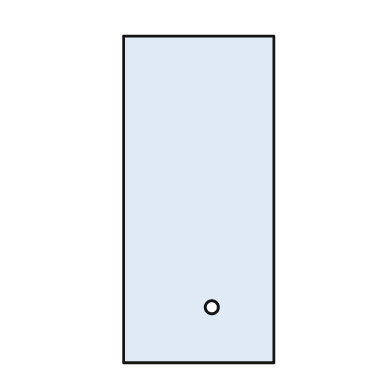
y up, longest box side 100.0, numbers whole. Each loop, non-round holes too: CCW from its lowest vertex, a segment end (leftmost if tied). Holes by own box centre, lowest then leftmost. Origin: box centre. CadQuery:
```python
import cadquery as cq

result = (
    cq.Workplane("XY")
    .moveTo(-23.0, -50.0)
    .lineTo(23.0, -50.0)
    .lineTo(23.0, 50.0)
    .lineTo(-23.0, 50.0)
    .close()
    .moveTo(4.0, -33.0)
    .circle(2.0)
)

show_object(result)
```